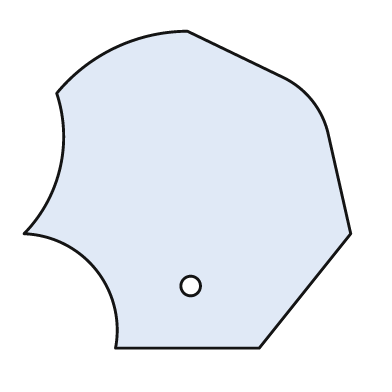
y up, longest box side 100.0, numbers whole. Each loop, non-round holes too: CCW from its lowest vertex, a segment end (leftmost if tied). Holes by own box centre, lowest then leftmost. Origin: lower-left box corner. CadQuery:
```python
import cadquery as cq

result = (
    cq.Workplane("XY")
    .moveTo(28.0, 0.0)
    .lineTo(72.0, 0.0)
    .lineTo(100.0, 35.0)
    .lineTo(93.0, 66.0)
    .threePointArc((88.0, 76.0), (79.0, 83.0))
    .lineTo(50.0, 97.0)
    .threePointArc((28.0, 92.0), (10.0, 78.0))
    .threePointArc((11.0, 55.0), (0.0, 35.0))
    .threePointArc((22.0, 24.0), (28.0, 0.0))
    .close()
    .moveTo(51.0, 19.0)
    .circle(3.0)
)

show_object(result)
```